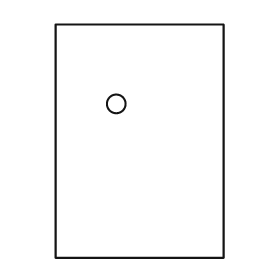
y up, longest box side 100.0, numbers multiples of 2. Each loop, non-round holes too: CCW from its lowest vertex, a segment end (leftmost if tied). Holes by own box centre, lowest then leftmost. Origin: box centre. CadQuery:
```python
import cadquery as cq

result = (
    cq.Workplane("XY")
    .moveTo(-36.0, -50.0)
    .lineTo(36.0, -50.0)
    .lineTo(36.0, 50.0)
    .lineTo(-36.0, 50.0)
    .close()
    .moveTo(-10.0, 16.0)
    .circle(4.0)
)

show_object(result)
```